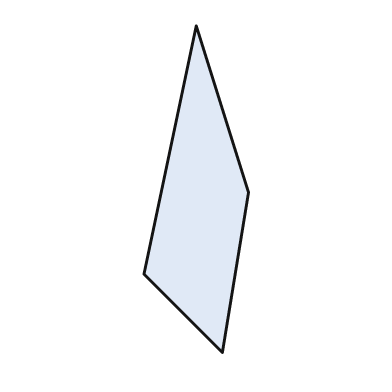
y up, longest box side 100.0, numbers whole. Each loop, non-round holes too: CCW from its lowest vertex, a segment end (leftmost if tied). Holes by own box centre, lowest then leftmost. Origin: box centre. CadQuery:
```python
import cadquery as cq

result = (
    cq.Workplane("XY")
    .moveTo(8.0, -50.0)
    .lineTo(16.0, -1.0)
    .lineTo(0.0, 50.0)
    .lineTo(-16.0, -26.0)
    .close()
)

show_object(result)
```